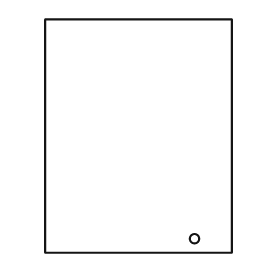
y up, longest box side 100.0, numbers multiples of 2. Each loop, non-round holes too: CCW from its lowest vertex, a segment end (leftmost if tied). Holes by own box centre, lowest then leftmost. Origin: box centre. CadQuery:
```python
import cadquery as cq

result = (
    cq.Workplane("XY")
    .moveTo(-40.0, -50.0)
    .lineTo(40.0, -50.0)
    .lineTo(40.0, 50.0)
    .lineTo(-40.0, 50.0)
    .close()
    .moveTo(24.0, -44.0)
    .circle(2.0)
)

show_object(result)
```